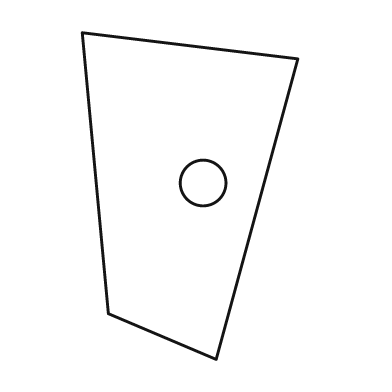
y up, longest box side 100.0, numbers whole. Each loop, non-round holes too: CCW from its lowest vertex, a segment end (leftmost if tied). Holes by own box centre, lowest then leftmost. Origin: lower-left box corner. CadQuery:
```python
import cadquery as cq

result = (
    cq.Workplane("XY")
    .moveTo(41.0, 0.0)
    .lineTo(66.0, 92.0)
    .lineTo(0.0, 100.0)
    .lineTo(8.0, 14.0)
    .close()
    .moveTo(37.0, 54.0)
    .circle(7.0)
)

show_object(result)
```